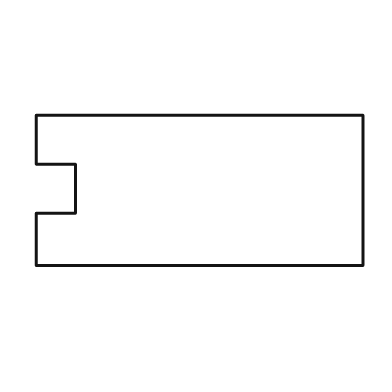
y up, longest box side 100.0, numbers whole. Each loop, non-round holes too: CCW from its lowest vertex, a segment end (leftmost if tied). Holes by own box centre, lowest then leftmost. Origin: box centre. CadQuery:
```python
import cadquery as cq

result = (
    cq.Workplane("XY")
    .moveTo(-50.0, -23.0)
    .lineTo(50.0, -23.0)
    .lineTo(50.0, 23.0)
    .lineTo(-50.0, 23.0)
    .lineTo(-50.0, 8.0)
    .lineTo(-38.0, 8.0)
    .lineTo(-38.0, -7.0)
    .lineTo(-50.0, -7.0)
    .close()
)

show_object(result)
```